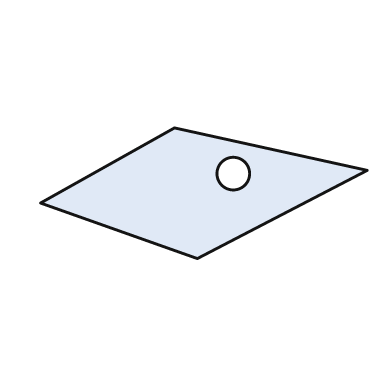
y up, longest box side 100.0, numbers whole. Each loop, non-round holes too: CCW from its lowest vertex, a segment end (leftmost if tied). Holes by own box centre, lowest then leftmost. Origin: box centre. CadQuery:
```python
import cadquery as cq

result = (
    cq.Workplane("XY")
    .moveTo(-2.0, -20.0)
    .lineTo(50.0, 7.0)
    .lineTo(-9.0, 20.0)
    .lineTo(-50.0, -3.0)
    .close()
    .moveTo(9.0, 6.0)
    .circle(5.0)
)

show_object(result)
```